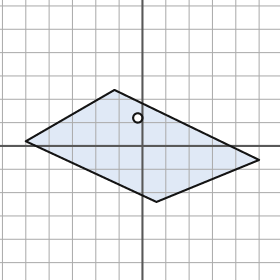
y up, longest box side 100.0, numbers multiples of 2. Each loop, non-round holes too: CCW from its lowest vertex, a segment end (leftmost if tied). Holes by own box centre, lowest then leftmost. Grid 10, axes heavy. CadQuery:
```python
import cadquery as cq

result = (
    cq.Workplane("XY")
    .moveTo(6.0, -24.0)
    .lineTo(50.0, -6.0)
    .lineTo(-12.0, 24.0)
    .lineTo(-50.0, 2.0)
    .close()
    .moveTo(-2.0, 12.0)
    .circle(2.0)
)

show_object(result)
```